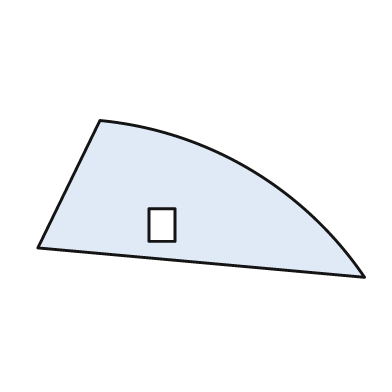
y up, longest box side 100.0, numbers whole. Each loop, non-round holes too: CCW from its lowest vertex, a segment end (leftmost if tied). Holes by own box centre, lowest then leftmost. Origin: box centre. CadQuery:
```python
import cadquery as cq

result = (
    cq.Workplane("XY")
    .moveTo(50.0, -24.0)
    .threePointArc((15.0, 9.0), (-31.0, 24.0))
    .lineTo(-50.0, -15.0)
    .close()
    .moveTo(-16.0, -13.0)
    .lineTo(-8.0, -13.0)
    .lineTo(-8.0, -3.0)
    .lineTo(-16.0, -3.0)
    .close()
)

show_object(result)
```